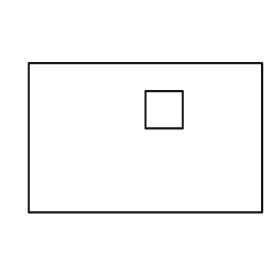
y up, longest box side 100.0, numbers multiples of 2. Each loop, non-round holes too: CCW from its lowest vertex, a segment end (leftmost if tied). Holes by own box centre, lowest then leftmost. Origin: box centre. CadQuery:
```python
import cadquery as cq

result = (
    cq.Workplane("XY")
    .moveTo(-50.0, -32.0)
    .lineTo(50.0, -32.0)
    .lineTo(50.0, 32.0)
    .lineTo(-50.0, 32.0)
    .close()
    .moveTo(0.0, 4.0)
    .lineTo(16.0, 4.0)
    .lineTo(16.0, 20.0)
    .lineTo(0.0, 20.0)
    .close()
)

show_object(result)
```